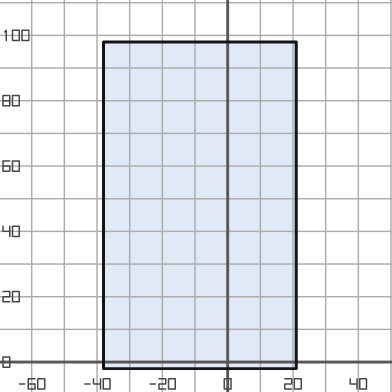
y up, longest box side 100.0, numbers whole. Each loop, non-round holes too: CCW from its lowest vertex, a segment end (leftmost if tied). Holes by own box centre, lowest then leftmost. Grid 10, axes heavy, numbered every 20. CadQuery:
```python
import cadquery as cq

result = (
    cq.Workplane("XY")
    .moveTo(-38.0, -2.0)
    .lineTo(21.0, -2.0)
    .lineTo(21.0, 98.0)
    .lineTo(-38.0, 98.0)
    .close()
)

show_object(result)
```